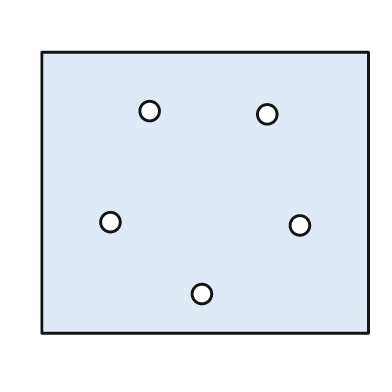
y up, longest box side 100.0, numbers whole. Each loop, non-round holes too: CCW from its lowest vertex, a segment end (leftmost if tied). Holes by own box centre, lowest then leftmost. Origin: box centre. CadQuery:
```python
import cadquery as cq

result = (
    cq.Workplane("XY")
    .moveTo(-50.0, -43.0)
    .lineTo(50.0, -43.0)
    .lineTo(50.0, 43.0)
    .lineTo(-50.0, 43.0)
    .close()
    .moveTo(-1.0, -31.0)
    .circle(3.0)
    .moveTo(29.0, -10.0)
    .circle(3.0)
    .moveTo(-29.0, -9.0)
    .circle(3.0)
    .moveTo(19.0, 24.0)
    .circle(3.0)
    .moveTo(-17.0, 25.0)
    .circle(3.0)
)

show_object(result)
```